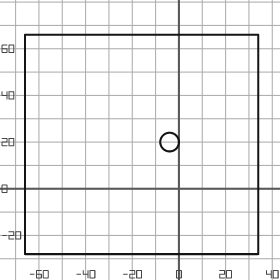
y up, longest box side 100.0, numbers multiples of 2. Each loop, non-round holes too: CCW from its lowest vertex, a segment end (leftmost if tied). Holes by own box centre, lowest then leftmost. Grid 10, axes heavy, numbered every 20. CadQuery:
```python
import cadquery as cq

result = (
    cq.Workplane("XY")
    .moveTo(-66.0, -28.0)
    .lineTo(34.0, -28.0)
    .lineTo(34.0, 66.0)
    .lineTo(-66.0, 66.0)
    .close()
    .moveTo(-4.0, 20.0)
    .circle(4.0)
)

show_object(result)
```